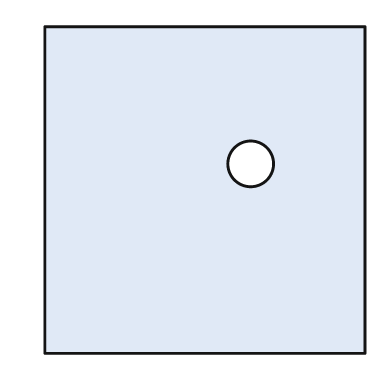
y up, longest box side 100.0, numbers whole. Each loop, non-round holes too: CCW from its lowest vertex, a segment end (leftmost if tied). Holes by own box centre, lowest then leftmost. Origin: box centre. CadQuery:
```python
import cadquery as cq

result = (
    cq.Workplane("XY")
    .moveTo(-49.0, -50.0)
    .lineTo(49.0, -50.0)
    .lineTo(49.0, 50.0)
    .lineTo(-49.0, 50.0)
    .close()
    .moveTo(14.0, 8.0)
    .circle(7.0)
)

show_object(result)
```